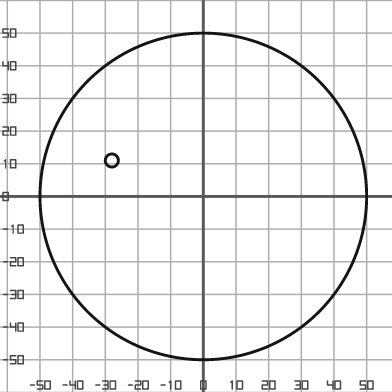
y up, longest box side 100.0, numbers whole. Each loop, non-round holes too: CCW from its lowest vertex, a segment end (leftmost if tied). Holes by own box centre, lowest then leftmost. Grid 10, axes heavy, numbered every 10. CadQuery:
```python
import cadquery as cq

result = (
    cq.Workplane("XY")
    .moveTo(0.0, 0.0)
    .circle(50.0)
    .moveTo(-28.0, 11.0)
    .circle(2.0)
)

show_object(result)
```